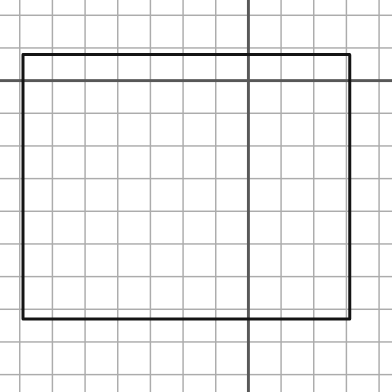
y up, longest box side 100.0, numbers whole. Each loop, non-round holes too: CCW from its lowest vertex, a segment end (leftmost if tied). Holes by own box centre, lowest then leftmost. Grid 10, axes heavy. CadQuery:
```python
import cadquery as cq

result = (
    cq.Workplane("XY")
    .moveTo(-69.0, -73.0)
    .lineTo(31.0, -73.0)
    .lineTo(31.0, 8.0)
    .lineTo(-69.0, 8.0)
    .close()
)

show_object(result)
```